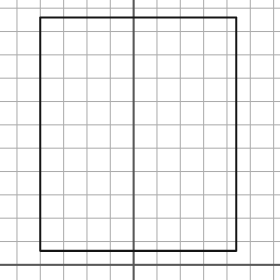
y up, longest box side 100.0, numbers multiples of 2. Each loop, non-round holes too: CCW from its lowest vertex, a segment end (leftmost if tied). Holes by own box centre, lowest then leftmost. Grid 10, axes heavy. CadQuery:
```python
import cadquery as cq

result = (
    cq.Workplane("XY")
    .moveTo(-40.0, 6.0)
    .lineTo(44.0, 6.0)
    .lineTo(44.0, 106.0)
    .lineTo(-40.0, 106.0)
    .close()
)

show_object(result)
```